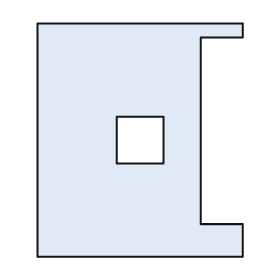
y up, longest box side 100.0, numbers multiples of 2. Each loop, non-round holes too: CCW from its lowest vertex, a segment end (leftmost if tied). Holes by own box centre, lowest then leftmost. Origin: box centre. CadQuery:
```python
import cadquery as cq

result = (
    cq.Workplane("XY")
    .moveTo(-44.0, -50.0)
    .lineTo(44.0, -50.0)
    .lineTo(44.0, -36.0)
    .lineTo(26.0, -36.0)
    .lineTo(26.0, 44.0)
    .lineTo(44.0, 44.0)
    .lineTo(44.0, 50.0)
    .lineTo(-44.0, 50.0)
    .close()
    .moveTo(-10.0, -10.0)
    .lineTo(10.0, -10.0)
    .lineTo(10.0, 10.0)
    .lineTo(-10.0, 10.0)
    .close()
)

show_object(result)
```